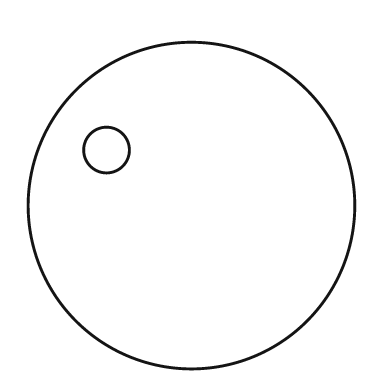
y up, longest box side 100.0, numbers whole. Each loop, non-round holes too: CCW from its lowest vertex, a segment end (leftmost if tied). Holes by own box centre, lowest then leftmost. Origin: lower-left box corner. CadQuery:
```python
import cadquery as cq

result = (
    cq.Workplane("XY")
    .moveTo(50.0, 50.0)
    .circle(50.0)
    .moveTo(24.0, 67.0)
    .circle(7.0)
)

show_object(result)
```